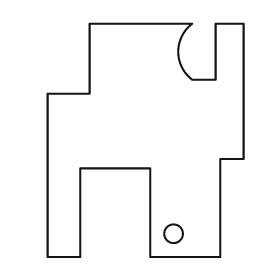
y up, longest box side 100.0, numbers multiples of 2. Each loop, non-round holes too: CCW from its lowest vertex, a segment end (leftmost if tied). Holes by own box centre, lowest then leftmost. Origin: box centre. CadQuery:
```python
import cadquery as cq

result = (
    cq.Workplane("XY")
    .moveTo(-42.0, -50.0)
    .lineTo(-28.0, -50.0)
    .lineTo(-28.0, -12.0)
    .lineTo(2.0, -12.0)
    .lineTo(2.0, -50.0)
    .lineTo(32.0, -50.0)
    .lineTo(32.0, -8.0)
    .lineTo(42.0, -8.0)
    .lineTo(42.0, 50.0)
    .lineTo(30.0, 50.0)
    .lineTo(30.0, 26.0)
    .lineTo(20.0, 26.0)
    .threePointArc((14.0, 38.0), (20.0, 50.0))
    .lineTo(-24.0, 50.0)
    .lineTo(-24.0, 20.0)
    .lineTo(-42.0, 20.0)
    .close()
    .moveTo(12.0, -40.0)
    .circle(4.0)
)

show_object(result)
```